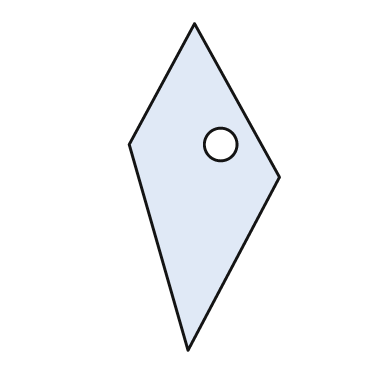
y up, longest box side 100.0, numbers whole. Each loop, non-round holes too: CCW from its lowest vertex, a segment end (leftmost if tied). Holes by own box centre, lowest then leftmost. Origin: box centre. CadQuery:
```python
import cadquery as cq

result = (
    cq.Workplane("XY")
    .moveTo(-5.0, -50.0)
    .lineTo(23.0, 3.0)
    .lineTo(-3.0, 50.0)
    .lineTo(-23.0, 13.0)
    .close()
    .moveTo(5.0, 13.0)
    .circle(5.0)
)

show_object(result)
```